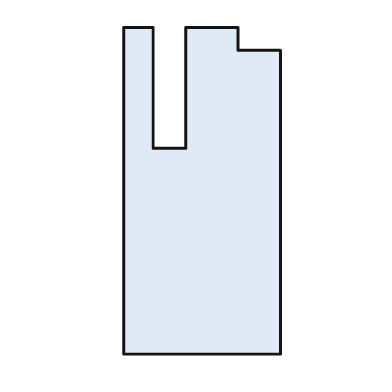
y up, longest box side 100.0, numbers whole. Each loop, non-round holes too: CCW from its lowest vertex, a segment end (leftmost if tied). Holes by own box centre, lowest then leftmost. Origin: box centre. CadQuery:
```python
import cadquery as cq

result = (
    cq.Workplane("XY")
    .moveTo(-24.0, -50.0)
    .lineTo(24.0, -50.0)
    .lineTo(24.0, 43.0)
    .lineTo(11.0, 43.0)
    .lineTo(11.0, 50.0)
    .lineTo(-5.0, 50.0)
    .lineTo(-5.0, 13.0)
    .lineTo(-15.0, 13.0)
    .lineTo(-15.0, 50.0)
    .lineTo(-24.0, 50.0)
    .close()
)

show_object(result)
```